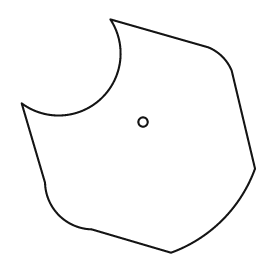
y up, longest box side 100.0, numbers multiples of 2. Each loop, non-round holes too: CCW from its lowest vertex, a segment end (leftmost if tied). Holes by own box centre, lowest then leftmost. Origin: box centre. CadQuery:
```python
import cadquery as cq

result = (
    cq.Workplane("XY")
    .moveTo(14.0, -50.0)
    .threePointArc((36.0, -36.0), (50.0, -14.0))
    .lineTo(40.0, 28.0)
    .threePointArc((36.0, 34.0), (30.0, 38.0))
    .lineTo(-12.0, 50.0)
    .threePointArc((-16.0, 16.0), (-50.0, 14.0))
    .lineTo(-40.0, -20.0)
    .threePointArc((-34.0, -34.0), (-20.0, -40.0))
    .close()
    .moveTo(2.0, 6.0)
    .circle(2.0)
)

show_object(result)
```